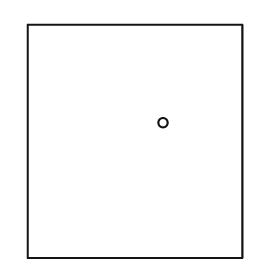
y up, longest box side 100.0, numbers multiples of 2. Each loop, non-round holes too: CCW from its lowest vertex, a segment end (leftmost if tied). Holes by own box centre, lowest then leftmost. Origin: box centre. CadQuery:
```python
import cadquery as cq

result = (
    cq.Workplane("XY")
    .moveTo(-46.0, -50.0)
    .lineTo(46.0, -50.0)
    .lineTo(46.0, 50.0)
    .lineTo(-46.0, 50.0)
    .close()
    .moveTo(12.0, 8.0)
    .circle(2.0)
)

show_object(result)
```